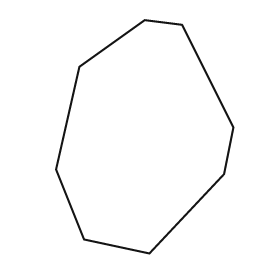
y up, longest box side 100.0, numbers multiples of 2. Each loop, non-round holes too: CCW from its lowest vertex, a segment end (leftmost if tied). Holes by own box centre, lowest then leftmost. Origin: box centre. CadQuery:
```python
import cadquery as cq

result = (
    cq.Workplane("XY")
    .moveTo(2.0, -50.0)
    .lineTo(34.0, -16.0)
    .lineTo(38.0, 4.0)
    .lineTo(16.0, 48.0)
    .lineTo(0.0, 50.0)
    .lineTo(-28.0, 30.0)
    .lineTo(-38.0, -14.0)
    .lineTo(-26.0, -44.0)
    .close()
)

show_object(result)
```